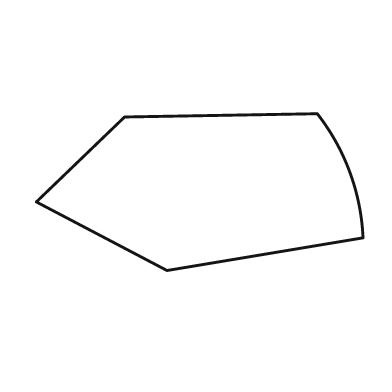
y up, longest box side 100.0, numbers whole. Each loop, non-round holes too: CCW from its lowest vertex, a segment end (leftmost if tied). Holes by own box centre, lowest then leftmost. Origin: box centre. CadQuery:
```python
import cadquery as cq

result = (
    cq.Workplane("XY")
    .moveTo(-10.0, -24.0)
    .lineTo(50.0, -14.0)
    .threePointArc((46.0, 6.0), (36.0, 24.0))
    .lineTo(-23.0, 23.0)
    .lineTo(-50.0, -3.0)
    .close()
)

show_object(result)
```